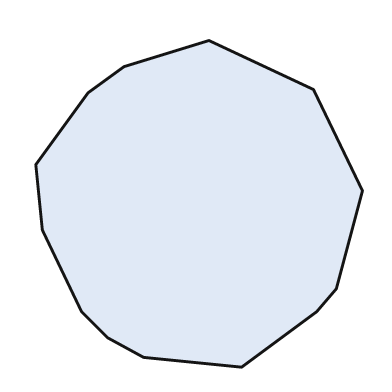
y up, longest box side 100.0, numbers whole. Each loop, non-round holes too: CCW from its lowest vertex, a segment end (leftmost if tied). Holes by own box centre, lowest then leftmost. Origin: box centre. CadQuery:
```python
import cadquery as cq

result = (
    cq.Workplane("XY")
    .moveTo(13.0, -50.0)
    .lineTo(36.0, -33.0)
    .lineTo(42.0, -26.0)
    .lineTo(50.0, 4.0)
    .lineTo(35.0, 35.0)
    .lineTo(3.0, 50.0)
    .lineTo(-23.0, 42.0)
    .lineTo(-34.0, 34.0)
    .lineTo(-50.0, 12.0)
    .lineTo(-48.0, -8.0)
    .lineTo(-36.0, -33.0)
    .lineTo(-28.0, -41.0)
    .lineTo(-17.0, -47.0)
    .close()
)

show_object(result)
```